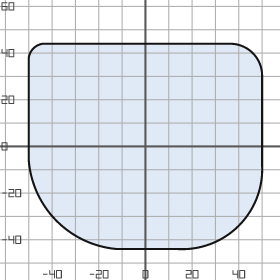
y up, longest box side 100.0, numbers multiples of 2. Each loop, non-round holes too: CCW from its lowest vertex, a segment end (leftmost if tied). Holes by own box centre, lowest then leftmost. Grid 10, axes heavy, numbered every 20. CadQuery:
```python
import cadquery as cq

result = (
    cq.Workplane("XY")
    .moveTo(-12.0, -44.0)
    .lineTo(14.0, -44.0)
    .threePointArc((40.0, -34.0), (50.0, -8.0))
    .lineTo(50.0, 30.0)
    .threePointArc((46.0, 40.0), (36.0, 44.0))
    .lineTo(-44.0, 44.0)
    .threePointArc((-48.0, 42.0), (-50.0, 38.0))
    .lineTo(-50.0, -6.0)
    .threePointArc((-38.0, -32.0), (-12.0, -44.0))
    .close()
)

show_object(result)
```